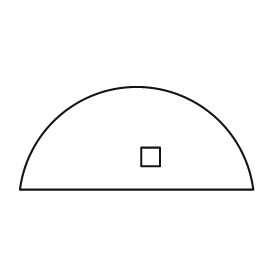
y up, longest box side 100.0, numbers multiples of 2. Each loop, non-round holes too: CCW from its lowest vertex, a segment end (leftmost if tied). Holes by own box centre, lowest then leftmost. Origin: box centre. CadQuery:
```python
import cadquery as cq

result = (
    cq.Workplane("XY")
    .moveTo(-50.0, -22.0)
    .lineTo(50.0, -22.0)
    .threePointArc((0.0, 22.0), (-50.0, -22.0))
    .close()
    .moveTo(2.0, -12.0)
    .lineTo(10.0, -12.0)
    .lineTo(10.0, -4.0)
    .lineTo(2.0, -4.0)
    .close()
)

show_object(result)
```